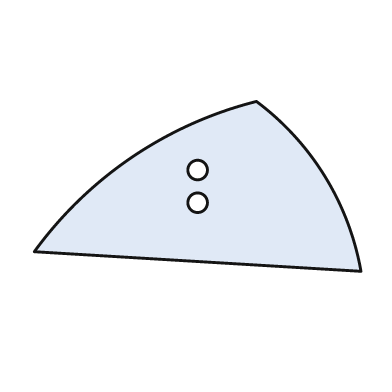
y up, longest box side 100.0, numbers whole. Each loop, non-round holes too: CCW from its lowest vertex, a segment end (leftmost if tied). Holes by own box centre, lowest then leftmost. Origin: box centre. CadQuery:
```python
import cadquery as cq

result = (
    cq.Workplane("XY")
    .moveTo(50.0, -26.0)
    .threePointArc((39.0, 3.0), (18.0, 26.0))
    .threePointArc((-20.0, 9.0), (-50.0, -20.0))
    .close()
    .moveTo(0.0, -5.0)
    .circle(3.0)
    .moveTo(0.0, 5.0)
    .circle(3.0)
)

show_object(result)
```